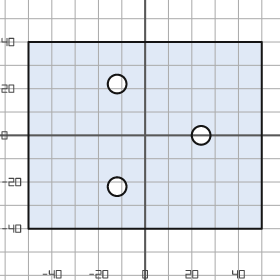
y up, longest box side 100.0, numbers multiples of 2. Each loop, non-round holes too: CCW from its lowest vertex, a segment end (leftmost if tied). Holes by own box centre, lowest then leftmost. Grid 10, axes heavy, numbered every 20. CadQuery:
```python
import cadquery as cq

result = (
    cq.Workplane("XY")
    .moveTo(-50.0, -40.0)
    .lineTo(50.0, -40.0)
    .lineTo(50.0, 40.0)
    .lineTo(-50.0, 40.0)
    .close()
    .moveTo(-12.0, -22.0)
    .circle(4.0)
    .moveTo(24.0, 0.0)
    .circle(4.0)
    .moveTo(-12.0, 22.0)
    .circle(4.0)
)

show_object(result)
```